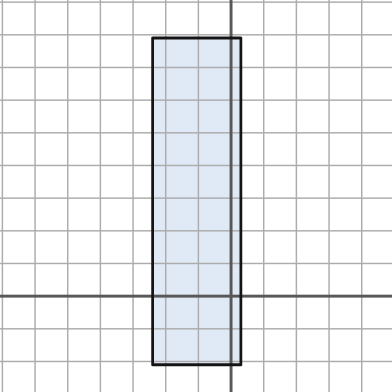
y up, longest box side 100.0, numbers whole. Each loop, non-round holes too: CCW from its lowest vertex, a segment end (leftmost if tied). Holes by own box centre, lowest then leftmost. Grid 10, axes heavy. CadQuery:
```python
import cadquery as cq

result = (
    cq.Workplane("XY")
    .moveTo(-24.0, -21.0)
    .lineTo(3.0, -21.0)
    .lineTo(3.0, 79.0)
    .lineTo(-24.0, 79.0)
    .close()
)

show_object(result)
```